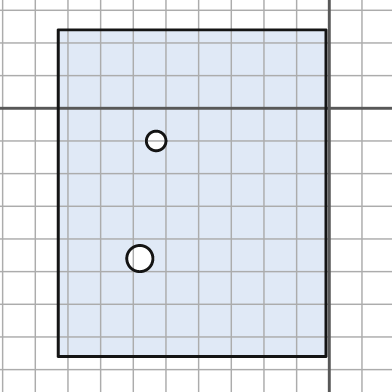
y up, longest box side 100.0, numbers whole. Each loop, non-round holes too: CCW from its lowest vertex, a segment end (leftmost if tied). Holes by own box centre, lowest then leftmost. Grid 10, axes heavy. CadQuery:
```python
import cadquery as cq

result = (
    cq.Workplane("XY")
    .moveTo(-83.0, -76.0)
    .lineTo(-1.0, -76.0)
    .lineTo(-1.0, 24.0)
    .lineTo(-83.0, 24.0)
    .close()
    .moveTo(-58.0, -46.0)
    .circle(4.0)
    .moveTo(-53.0, -10.0)
    .circle(3.0)
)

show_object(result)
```